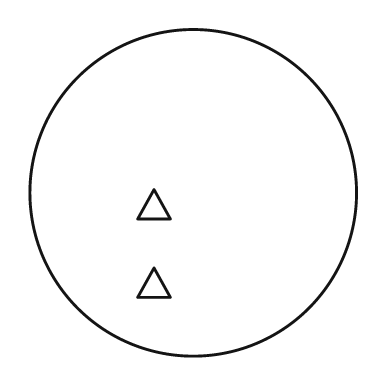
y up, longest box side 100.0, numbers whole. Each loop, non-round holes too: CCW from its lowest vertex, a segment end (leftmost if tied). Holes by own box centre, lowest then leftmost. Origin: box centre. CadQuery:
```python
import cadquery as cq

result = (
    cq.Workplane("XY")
    .moveTo(0.0, 0.0)
    .circle(50.0)
    .moveTo(-17.0, -32.0)
    .lineTo(-7.0, -32.0)
    .lineTo(-12.0, -23.0)
    .close()
    .moveTo(-17.0, -8.0)
    .lineTo(-7.0, -8.0)
    .lineTo(-12.0, 1.0)
    .close()
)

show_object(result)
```